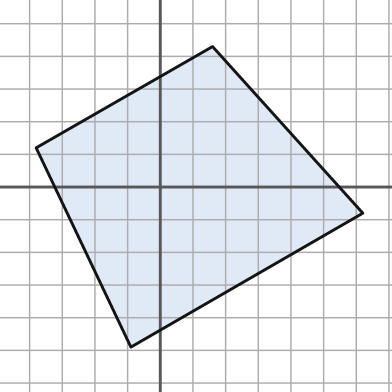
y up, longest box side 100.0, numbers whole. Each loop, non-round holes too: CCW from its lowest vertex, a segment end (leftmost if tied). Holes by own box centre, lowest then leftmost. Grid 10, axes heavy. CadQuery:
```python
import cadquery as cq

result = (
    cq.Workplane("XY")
    .moveTo(-9.0, -49.0)
    .lineTo(62.0, -8.0)
    .lineTo(16.0, 43.0)
    .lineTo(-38.0, 12.0)
    .close()
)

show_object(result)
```